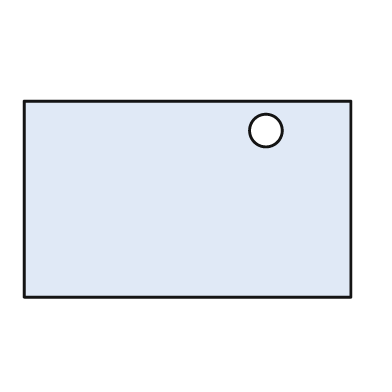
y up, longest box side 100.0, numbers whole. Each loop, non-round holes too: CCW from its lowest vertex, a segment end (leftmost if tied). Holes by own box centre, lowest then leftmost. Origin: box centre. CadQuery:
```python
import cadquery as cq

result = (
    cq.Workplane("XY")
    .moveTo(-50.0, -30.0)
    .lineTo(50.0, -30.0)
    .lineTo(50.0, 30.0)
    .lineTo(-50.0, 30.0)
    .close()
    .moveTo(24.0, 21.0)
    .circle(5.0)
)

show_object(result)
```